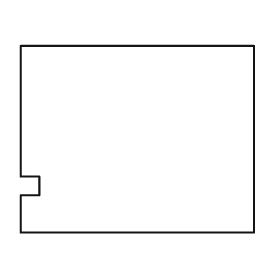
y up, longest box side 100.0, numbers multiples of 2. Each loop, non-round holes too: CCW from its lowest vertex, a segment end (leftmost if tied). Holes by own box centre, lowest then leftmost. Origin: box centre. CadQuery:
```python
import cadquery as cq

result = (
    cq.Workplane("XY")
    .moveTo(-50.0, -40.0)
    .lineTo(50.0, -40.0)
    .lineTo(50.0, 40.0)
    .lineTo(-50.0, 40.0)
    .lineTo(-50.0, -16.0)
    .lineTo(-42.0, -16.0)
    .lineTo(-42.0, -24.0)
    .lineTo(-50.0, -24.0)
    .close()
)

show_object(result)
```